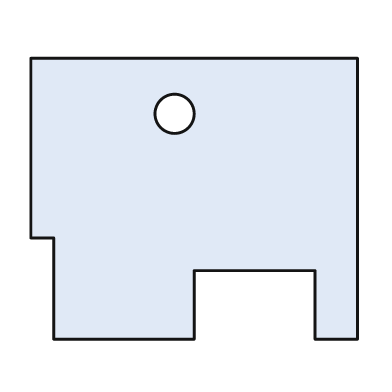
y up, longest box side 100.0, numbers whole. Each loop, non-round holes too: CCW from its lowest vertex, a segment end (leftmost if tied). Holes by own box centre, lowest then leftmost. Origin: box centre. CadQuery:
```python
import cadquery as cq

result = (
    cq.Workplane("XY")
    .moveTo(-43.0, -43.0)
    .lineTo(0.0, -43.0)
    .lineTo(0.0, -22.0)
    .lineTo(37.0, -22.0)
    .lineTo(37.0, -43.0)
    .lineTo(50.0, -43.0)
    .lineTo(50.0, 43.0)
    .lineTo(-50.0, 43.0)
    .lineTo(-50.0, -12.0)
    .lineTo(-43.0, -12.0)
    .close()
    .moveTo(-6.0, 26.0)
    .circle(6.0)
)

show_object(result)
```